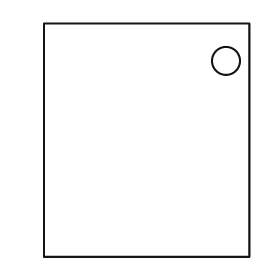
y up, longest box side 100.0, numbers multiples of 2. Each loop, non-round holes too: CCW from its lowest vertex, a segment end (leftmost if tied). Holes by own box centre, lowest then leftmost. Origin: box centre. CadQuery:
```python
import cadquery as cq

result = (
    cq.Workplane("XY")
    .moveTo(-44.0, -50.0)
    .lineTo(44.0, -50.0)
    .lineTo(44.0, 50.0)
    .lineTo(-44.0, 50.0)
    .close()
    .moveTo(34.0, 34.0)
    .circle(6.0)
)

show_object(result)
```